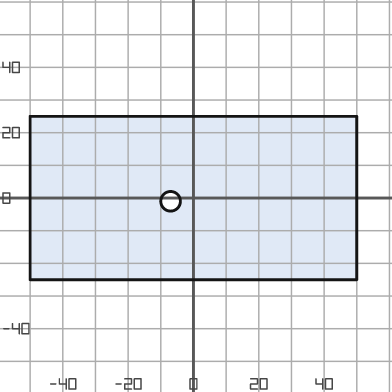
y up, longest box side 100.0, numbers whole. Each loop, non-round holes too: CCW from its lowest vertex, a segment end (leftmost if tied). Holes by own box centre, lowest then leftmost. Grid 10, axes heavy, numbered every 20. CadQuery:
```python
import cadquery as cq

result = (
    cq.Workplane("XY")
    .moveTo(-50.0, -25.0)
    .lineTo(50.0, -25.0)
    .lineTo(50.0, 25.0)
    .lineTo(-50.0, 25.0)
    .close()
    .moveTo(-7.0, -1.0)
    .circle(3.0)
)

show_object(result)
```